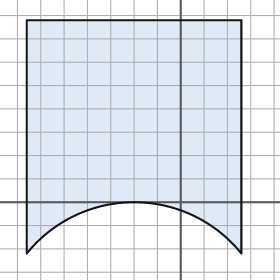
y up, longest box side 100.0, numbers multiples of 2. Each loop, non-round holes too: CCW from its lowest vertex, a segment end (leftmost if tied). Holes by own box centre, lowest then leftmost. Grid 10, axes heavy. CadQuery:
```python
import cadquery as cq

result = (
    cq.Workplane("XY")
    .moveTo(-66.0, -22.0)
    .threePointArc((-20.0, 0.0), (26.0, -22.0))
    .lineTo(26.0, 78.0)
    .lineTo(-66.0, 78.0)
    .close()
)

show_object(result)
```